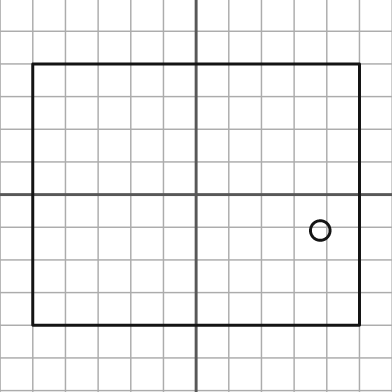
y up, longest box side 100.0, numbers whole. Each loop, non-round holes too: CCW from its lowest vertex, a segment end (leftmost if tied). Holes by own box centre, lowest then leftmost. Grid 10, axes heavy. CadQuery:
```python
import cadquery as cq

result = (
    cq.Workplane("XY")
    .moveTo(-50.0, -40.0)
    .lineTo(50.0, -40.0)
    .lineTo(50.0, 40.0)
    .lineTo(-50.0, 40.0)
    .close()
    .moveTo(38.0, -11.0)
    .circle(3.0)
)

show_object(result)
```